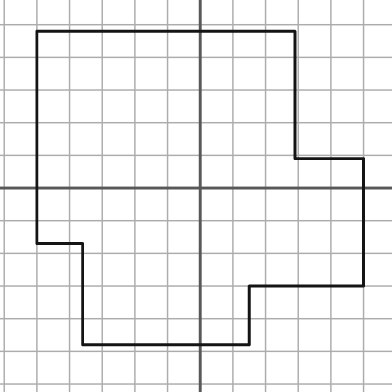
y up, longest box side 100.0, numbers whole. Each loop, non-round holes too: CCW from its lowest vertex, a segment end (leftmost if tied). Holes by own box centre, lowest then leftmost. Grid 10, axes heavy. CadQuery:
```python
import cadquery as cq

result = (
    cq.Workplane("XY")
    .moveTo(-36.0, -48.0)
    .lineTo(15.0, -48.0)
    .lineTo(15.0, -30.0)
    .lineTo(50.0, -30.0)
    .lineTo(50.0, 9.0)
    .lineTo(29.0, 9.0)
    .lineTo(29.0, 48.0)
    .lineTo(-50.0, 48.0)
    .lineTo(-50.0, -17.0)
    .lineTo(-36.0, -17.0)
    .close()
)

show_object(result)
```